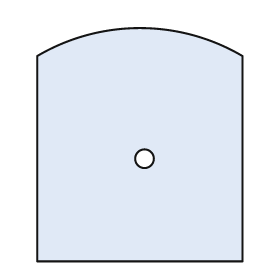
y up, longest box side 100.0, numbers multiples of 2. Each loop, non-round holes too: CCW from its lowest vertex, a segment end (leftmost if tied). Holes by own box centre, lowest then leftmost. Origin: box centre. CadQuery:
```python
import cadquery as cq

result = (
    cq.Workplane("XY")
    .moveTo(-44.0, -50.0)
    .lineTo(44.0, -50.0)
    .lineTo(44.0, 38.0)
    .threePointArc((0.0, 50.0), (-44.0, 38.0))
    .close()
    .moveTo(2.0, -6.0)
    .circle(4.0)
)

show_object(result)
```